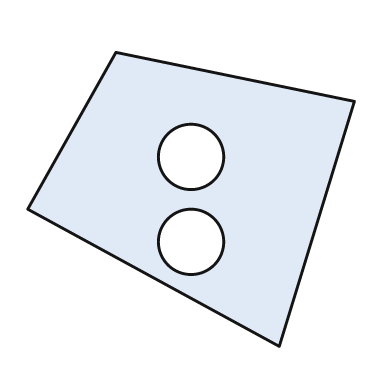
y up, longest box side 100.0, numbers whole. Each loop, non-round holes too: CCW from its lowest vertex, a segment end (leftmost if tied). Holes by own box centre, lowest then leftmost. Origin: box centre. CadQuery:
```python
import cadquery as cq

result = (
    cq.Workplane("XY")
    .moveTo(27.0, -45.0)
    .lineTo(50.0, 30.0)
    .lineTo(-23.0, 45.0)
    .lineTo(-50.0, -3.0)
    .close()
    .moveTo(0.0, -13.0)
    .circle(10.0)
    .moveTo(0.0, 13.0)
    .circle(10.0)
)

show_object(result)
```